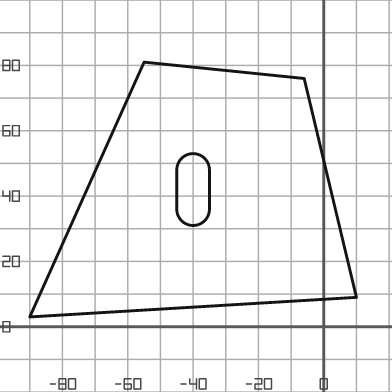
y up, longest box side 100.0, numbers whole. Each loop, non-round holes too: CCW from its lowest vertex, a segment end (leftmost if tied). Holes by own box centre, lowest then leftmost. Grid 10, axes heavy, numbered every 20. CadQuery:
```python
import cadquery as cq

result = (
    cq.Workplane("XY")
    .moveTo(-90.0, 3.0)
    .lineTo(10.0, 9.0)
    .lineTo(-6.0, 76.0)
    .lineTo(-55.0, 81.0)
    .close()
    .moveTo(-45.0, 36.0)
    .threePointArc((-40.0, 31.0), (-35.0, 36.0))
    .lineTo(-35.0, 48.0)
    .threePointArc((-40.0, 53.0), (-45.0, 48.0))
    .close()
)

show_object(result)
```